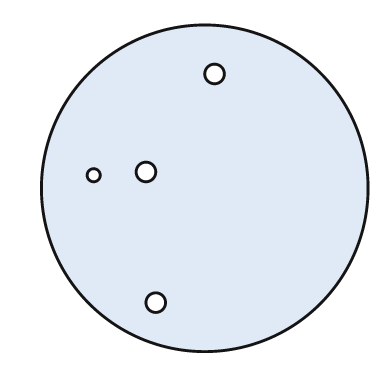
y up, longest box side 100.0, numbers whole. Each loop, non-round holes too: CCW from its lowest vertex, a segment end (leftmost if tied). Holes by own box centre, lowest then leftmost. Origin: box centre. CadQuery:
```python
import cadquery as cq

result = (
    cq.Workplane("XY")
    .moveTo(0.0, 0.0)
    .circle(50.0)
    .moveTo(-15.0, -35.0)
    .circle(3.0)
    .moveTo(-34.0, 4.0)
    .circle(2.0)
    .moveTo(-18.0, 5.0)
    .circle(3.0)
    .moveTo(3.0, 35.0)
    .circle(3.0)
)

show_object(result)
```